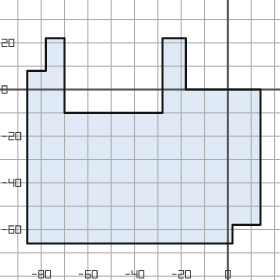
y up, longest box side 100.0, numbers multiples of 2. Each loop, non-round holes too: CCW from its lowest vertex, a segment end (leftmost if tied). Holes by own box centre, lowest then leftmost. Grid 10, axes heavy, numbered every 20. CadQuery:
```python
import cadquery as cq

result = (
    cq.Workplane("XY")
    .moveTo(-86.0, -66.0)
    .lineTo(2.0, -66.0)
    .lineTo(2.0, -58.0)
    .lineTo(14.0, -58.0)
    .lineTo(14.0, 0.0)
    .lineTo(-18.0, 0.0)
    .lineTo(-18.0, 22.0)
    .lineTo(-28.0, 22.0)
    .lineTo(-28.0, -10.0)
    .lineTo(-70.0, -10.0)
    .lineTo(-70.0, 22.0)
    .lineTo(-78.0, 22.0)
    .lineTo(-78.0, 8.0)
    .lineTo(-86.0, 8.0)
    .close()
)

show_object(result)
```